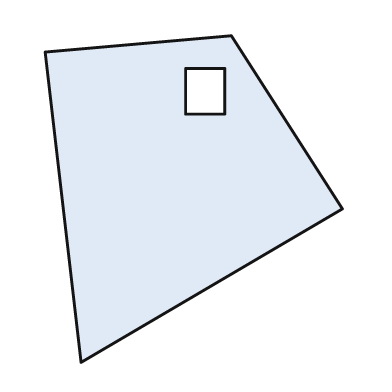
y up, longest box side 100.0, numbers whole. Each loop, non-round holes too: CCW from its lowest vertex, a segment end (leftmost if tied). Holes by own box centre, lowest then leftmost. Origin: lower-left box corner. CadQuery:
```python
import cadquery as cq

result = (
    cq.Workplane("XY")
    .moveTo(11.0, 0.0)
    .lineTo(91.0, 47.0)
    .lineTo(57.0, 100.0)
    .lineTo(0.0, 95.0)
    .close()
    .moveTo(43.0, 76.0)
    .lineTo(55.0, 76.0)
    .lineTo(55.0, 90.0)
    .lineTo(43.0, 90.0)
    .close()
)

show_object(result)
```